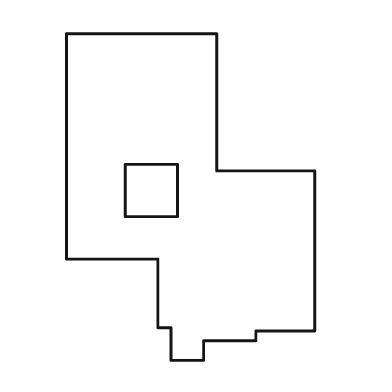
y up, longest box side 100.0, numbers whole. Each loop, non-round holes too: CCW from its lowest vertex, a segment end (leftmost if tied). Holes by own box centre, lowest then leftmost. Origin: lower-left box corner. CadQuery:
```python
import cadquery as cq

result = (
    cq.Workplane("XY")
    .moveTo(32.0, 0.0)
    .lineTo(42.0, 0.0)
    .lineTo(42.0, 6.0)
    .lineTo(58.0, 6.0)
    .lineTo(58.0, 9.0)
    .lineTo(76.0, 9.0)
    .lineTo(76.0, 58.0)
    .lineTo(46.0, 58.0)
    .lineTo(46.0, 100.0)
    .lineTo(0.0, 100.0)
    .lineTo(0.0, 31.0)
    .lineTo(28.0, 31.0)
    .lineTo(28.0, 10.0)
    .lineTo(32.0, 10.0)
    .close()
    .moveTo(18.0, 44.0)
    .lineTo(34.0, 44.0)
    .lineTo(34.0, 60.0)
    .lineTo(18.0, 60.0)
    .close()
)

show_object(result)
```